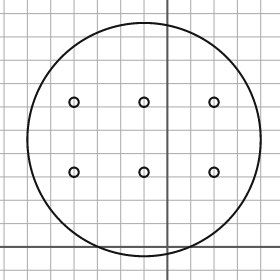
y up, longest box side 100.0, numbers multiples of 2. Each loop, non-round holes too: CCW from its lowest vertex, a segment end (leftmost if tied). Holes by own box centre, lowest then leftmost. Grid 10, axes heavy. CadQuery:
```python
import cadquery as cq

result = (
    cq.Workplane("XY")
    .moveTo(-10.0, 46.0)
    .circle(50.0)
    .moveTo(-40.0, 32.0)
    .circle(2.0)
    .moveTo(-10.0, 32.0)
    .circle(2.0)
    .moveTo(20.0, 32.0)
    .circle(2.0)
    .moveTo(-40.0, 62.0)
    .circle(2.0)
    .moveTo(-10.0, 62.0)
    .circle(2.0)
    .moveTo(20.0, 62.0)
    .circle(2.0)
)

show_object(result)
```